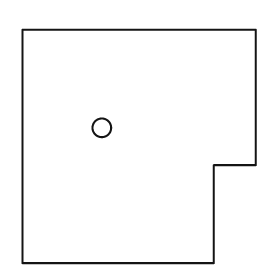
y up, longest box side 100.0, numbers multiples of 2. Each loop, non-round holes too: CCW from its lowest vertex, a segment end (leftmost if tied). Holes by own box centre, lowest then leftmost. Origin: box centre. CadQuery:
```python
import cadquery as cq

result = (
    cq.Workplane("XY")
    .moveTo(-50.0, -50.0)
    .lineTo(32.0, -50.0)
    .lineTo(32.0, -8.0)
    .lineTo(50.0, -8.0)
    .lineTo(50.0, 50.0)
    .lineTo(-50.0, 50.0)
    .close()
    .moveTo(-16.0, 8.0)
    .circle(4.0)
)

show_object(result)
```